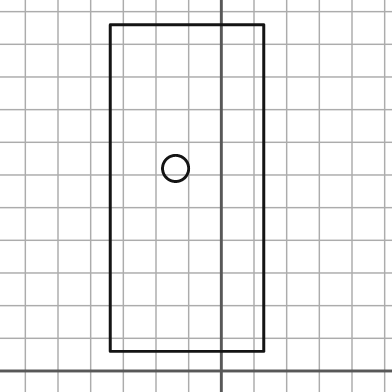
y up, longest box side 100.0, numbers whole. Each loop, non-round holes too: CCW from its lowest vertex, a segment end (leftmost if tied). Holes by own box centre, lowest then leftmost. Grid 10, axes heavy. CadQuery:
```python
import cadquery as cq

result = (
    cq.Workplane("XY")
    .moveTo(-34.0, 6.0)
    .lineTo(13.0, 6.0)
    .lineTo(13.0, 106.0)
    .lineTo(-34.0, 106.0)
    .close()
    .moveTo(-14.0, 62.0)
    .circle(4.0)
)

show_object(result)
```